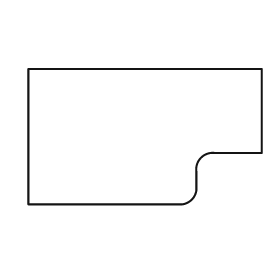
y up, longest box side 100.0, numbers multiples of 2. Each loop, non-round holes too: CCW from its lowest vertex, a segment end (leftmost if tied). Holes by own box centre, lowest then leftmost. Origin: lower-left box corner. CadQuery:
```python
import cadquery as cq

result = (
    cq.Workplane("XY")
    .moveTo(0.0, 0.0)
    .lineTo(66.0, 0.0)
    .threePointArc((70.0, 2.0), (72.0, 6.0))
    .lineTo(72.0, 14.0)
    .threePointArc((74.0, 20.0), (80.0, 22.0))
    .lineTo(100.0, 22.0)
    .lineTo(100.0, 58.0)
    .lineTo(0.0, 58.0)
    .close()
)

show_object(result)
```